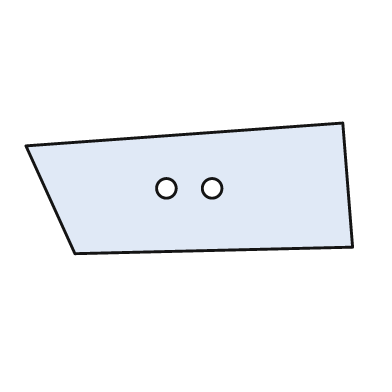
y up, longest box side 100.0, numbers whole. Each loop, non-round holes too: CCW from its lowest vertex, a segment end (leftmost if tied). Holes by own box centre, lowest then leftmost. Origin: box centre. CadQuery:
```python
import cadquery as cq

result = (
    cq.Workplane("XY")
    .moveTo(-35.0, -20.0)
    .lineTo(50.0, -18.0)
    .lineTo(47.0, 20.0)
    .lineTo(-50.0, 13.0)
    .close()
    .moveTo(-7.0, 0.0)
    .circle(3.0)
    .moveTo(7.0, 0.0)
    .circle(3.0)
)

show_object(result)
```